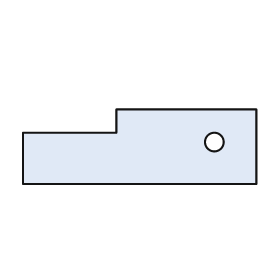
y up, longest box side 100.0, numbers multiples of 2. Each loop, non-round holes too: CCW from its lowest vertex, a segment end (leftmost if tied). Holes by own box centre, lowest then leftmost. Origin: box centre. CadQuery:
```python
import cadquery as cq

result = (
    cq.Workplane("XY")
    .moveTo(-50.0, -16.0)
    .lineTo(50.0, -16.0)
    .lineTo(50.0, 16.0)
    .lineTo(-10.0, 16.0)
    .lineTo(-10.0, 6.0)
    .lineTo(-50.0, 6.0)
    .close()
    .moveTo(32.0, 2.0)
    .circle(4.0)
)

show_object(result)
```